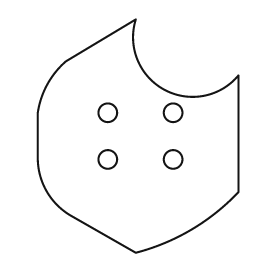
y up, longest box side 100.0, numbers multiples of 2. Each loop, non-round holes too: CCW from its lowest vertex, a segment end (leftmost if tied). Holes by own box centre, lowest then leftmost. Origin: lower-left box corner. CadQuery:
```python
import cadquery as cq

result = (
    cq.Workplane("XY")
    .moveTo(42.0, 0.0)
    .threePointArc((66.0, 10.0), (86.0, 26.0))
    .lineTo(86.0, 76.0)
    .threePointArc((54.0, 70.0), (42.0, 100.0))
    .lineTo(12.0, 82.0)
    .threePointArc((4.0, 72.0), (0.0, 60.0))
    .lineTo(0.0, 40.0)
    .threePointArc((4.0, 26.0), (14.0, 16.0))
    .close()
    .moveTo(30.0, 40.0)
    .circle(4.0)
    .moveTo(58.0, 40.0)
    .circle(4.0)
    .moveTo(30.0, 60.0)
    .circle(4.0)
    .moveTo(58.0, 60.0)
    .circle(4.0)
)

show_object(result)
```